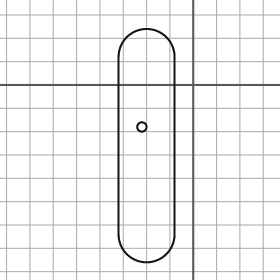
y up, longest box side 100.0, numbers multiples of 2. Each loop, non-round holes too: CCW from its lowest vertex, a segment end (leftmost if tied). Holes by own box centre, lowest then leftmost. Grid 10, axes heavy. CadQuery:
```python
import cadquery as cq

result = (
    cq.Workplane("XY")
    .moveTo(-32.0, -64.0)
    .threePointArc((-20.0, -76.0), (-8.0, -64.0))
    .lineTo(-8.0, 12.0)
    .threePointArc((-20.0, 24.0), (-32.0, 12.0))
    .close()
    .moveTo(-22.0, -18.0)
    .circle(2.0)
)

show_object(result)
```